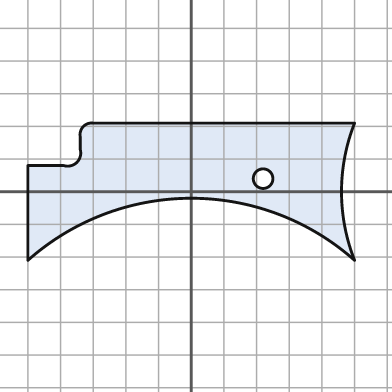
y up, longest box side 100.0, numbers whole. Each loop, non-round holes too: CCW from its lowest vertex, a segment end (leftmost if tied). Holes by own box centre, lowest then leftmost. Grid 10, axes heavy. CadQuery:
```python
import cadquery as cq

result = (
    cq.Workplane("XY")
    .moveTo(-50.0, -21.0)
    .threePointArc((0.0, -2.0), (50.0, -21.0))
    .threePointArc((46.0, 0.0), (50.0, 21.0))
    .lineTo(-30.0, 21.0)
    .threePointArc((-33.0, 20.0), (-34.0, 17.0))
    .lineTo(-34.0, 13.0)
    .threePointArc((-35.0, 9.0), (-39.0, 8.0))
    .lineTo(-50.0, 8.0)
    .close()
    .moveTo(22.0, 4.0)
    .circle(3.0)
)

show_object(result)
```